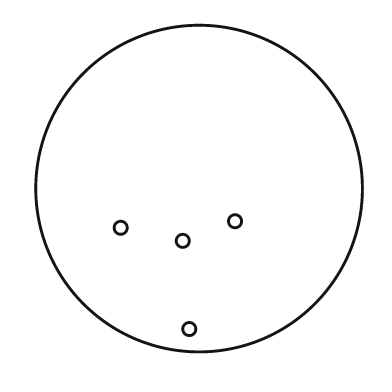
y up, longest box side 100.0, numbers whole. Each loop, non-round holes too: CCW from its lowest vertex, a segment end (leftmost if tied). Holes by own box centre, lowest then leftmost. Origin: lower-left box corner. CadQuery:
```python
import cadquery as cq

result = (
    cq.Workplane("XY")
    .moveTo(50.0, 50.0)
    .circle(50.0)
    .moveTo(47.0, 7.0)
    .circle(2.0)
    .moveTo(45.0, 34.0)
    .circle(2.0)
    .moveTo(26.0, 38.0)
    .circle(2.0)
    .moveTo(61.0, 40.0)
    .circle(2.0)
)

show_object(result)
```